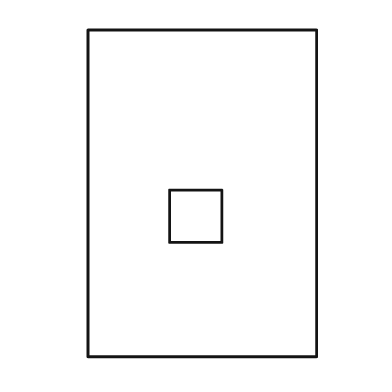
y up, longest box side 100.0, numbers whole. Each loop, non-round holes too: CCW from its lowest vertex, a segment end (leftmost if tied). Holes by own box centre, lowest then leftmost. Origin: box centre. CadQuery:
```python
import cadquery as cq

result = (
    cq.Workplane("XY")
    .moveTo(-35.0, -50.0)
    .lineTo(35.0, -50.0)
    .lineTo(35.0, 50.0)
    .lineTo(-35.0, 50.0)
    .close()
    .moveTo(-10.0, -15.0)
    .lineTo(6.0, -15.0)
    .lineTo(6.0, 1.0)
    .lineTo(-10.0, 1.0)
    .close()
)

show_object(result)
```